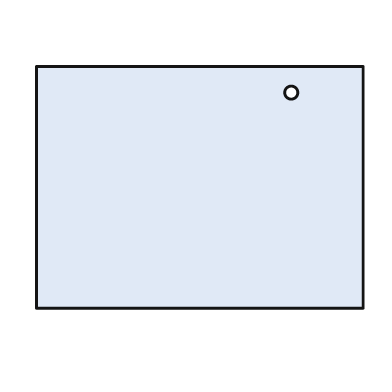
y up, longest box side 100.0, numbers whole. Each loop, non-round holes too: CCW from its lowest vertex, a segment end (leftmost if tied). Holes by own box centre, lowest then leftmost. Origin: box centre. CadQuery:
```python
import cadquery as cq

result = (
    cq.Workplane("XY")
    .moveTo(-50.0, -37.0)
    .lineTo(50.0, -37.0)
    .lineTo(50.0, 37.0)
    .lineTo(-50.0, 37.0)
    .close()
    .moveTo(28.0, 29.0)
    .circle(2.0)
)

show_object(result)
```